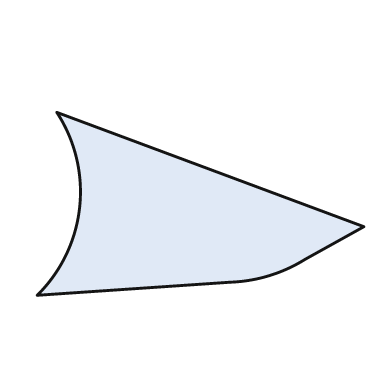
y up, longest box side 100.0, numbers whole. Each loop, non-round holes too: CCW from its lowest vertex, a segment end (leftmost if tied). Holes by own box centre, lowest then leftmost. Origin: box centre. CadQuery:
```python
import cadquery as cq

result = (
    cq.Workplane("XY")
    .moveTo(-50.0, -28.0)
    .lineTo(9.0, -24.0)
    .threePointArc((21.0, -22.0), (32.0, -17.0))
    .lineTo(50.0, -7.0)
    .lineTo(-44.0, 28.0)
    .threePointArc((-37.0, -1.0), (-50.0, -28.0))
    .close()
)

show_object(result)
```